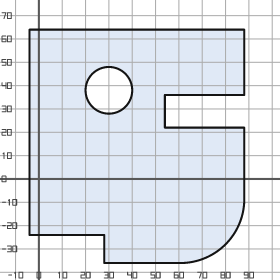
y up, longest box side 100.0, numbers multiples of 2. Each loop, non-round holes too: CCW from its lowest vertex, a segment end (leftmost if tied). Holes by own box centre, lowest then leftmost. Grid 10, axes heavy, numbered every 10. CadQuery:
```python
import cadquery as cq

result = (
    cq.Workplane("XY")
    .moveTo(28.0, -36.0)
    .lineTo(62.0, -36.0)
    .threePointArc((80.0, -28.0), (88.0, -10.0))
    .lineTo(88.0, 22.0)
    .lineTo(54.0, 22.0)
    .lineTo(54.0, 36.0)
    .lineTo(88.0, 36.0)
    .lineTo(88.0, 64.0)
    .lineTo(-4.0, 64.0)
    .lineTo(-4.0, -24.0)
    .lineTo(28.0, -24.0)
    .close()
    .moveTo(30.0, 38.0)
    .circle(10.0)
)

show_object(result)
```